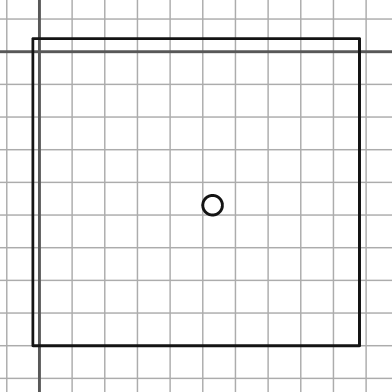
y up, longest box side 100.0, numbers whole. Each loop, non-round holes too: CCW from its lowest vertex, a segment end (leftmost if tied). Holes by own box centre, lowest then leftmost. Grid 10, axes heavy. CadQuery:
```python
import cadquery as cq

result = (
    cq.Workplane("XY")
    .moveTo(-2.0, -90.0)
    .lineTo(98.0, -90.0)
    .lineTo(98.0, 4.0)
    .lineTo(-2.0, 4.0)
    .close()
    .moveTo(53.0, -47.0)
    .circle(3.0)
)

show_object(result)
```